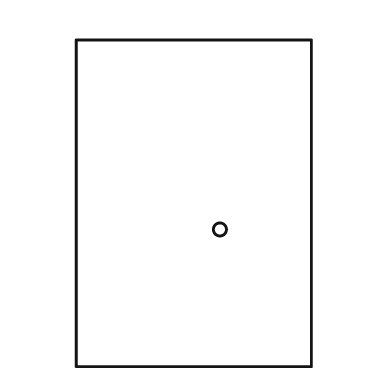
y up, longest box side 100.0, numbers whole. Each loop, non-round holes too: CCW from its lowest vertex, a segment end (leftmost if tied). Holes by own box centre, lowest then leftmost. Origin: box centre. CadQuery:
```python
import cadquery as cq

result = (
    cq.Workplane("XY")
    .moveTo(-36.0, -50.0)
    .lineTo(36.0, -50.0)
    .lineTo(36.0, 50.0)
    .lineTo(-36.0, 50.0)
    .close()
    .moveTo(8.0, -8.0)
    .circle(2.0)
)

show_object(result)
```